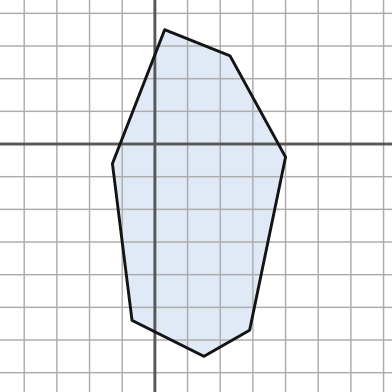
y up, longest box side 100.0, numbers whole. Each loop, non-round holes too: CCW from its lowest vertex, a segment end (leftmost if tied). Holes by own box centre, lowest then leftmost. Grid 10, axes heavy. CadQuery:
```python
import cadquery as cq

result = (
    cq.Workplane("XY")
    .moveTo(15.0, -65.0)
    .lineTo(29.0, -57.0)
    .lineTo(40.0, -4.0)
    .lineTo(23.0, 27.0)
    .lineTo(3.0, 35.0)
    .lineTo(-13.0, -6.0)
    .lineTo(-7.0, -54.0)
    .close()
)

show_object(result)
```